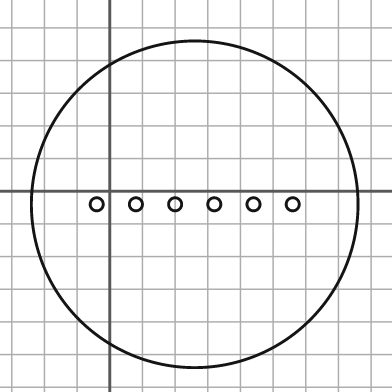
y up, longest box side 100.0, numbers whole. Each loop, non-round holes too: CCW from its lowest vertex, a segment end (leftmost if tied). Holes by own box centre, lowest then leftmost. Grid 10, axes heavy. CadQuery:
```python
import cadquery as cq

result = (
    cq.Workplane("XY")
    .moveTo(26.0, -4.0)
    .circle(50.0)
    .moveTo(-4.0, -4.0)
    .circle(2.0)
    .moveTo(8.0, -4.0)
    .circle(2.0)
    .moveTo(20.0, -4.0)
    .circle(2.0)
    .moveTo(32.0, -4.0)
    .circle(2.0)
    .moveTo(44.0, -4.0)
    .circle(2.0)
    .moveTo(56.0, -4.0)
    .circle(2.0)
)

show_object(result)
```